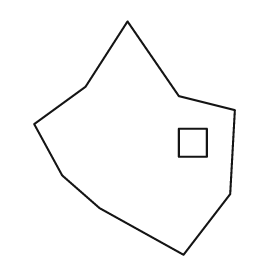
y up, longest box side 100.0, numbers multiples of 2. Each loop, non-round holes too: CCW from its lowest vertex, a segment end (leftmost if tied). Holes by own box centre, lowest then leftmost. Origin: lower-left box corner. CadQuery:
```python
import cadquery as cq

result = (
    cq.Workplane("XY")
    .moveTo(64.0, 0.0)
    .lineTo(84.0, 26.0)
    .lineTo(86.0, 62.0)
    .lineTo(62.0, 68.0)
    .lineTo(40.0, 100.0)
    .lineTo(22.0, 72.0)
    .lineTo(0.0, 56.0)
    .lineTo(12.0, 34.0)
    .lineTo(28.0, 20.0)
    .close()
    .moveTo(62.0, 42.0)
    .lineTo(74.0, 42.0)
    .lineTo(74.0, 54.0)
    .lineTo(62.0, 54.0)
    .close()
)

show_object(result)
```